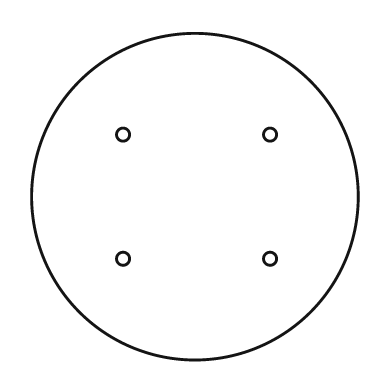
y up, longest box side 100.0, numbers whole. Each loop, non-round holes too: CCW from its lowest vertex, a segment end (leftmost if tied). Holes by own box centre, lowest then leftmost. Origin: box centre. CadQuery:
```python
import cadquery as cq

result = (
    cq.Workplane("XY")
    .moveTo(0.0, 0.0)
    .circle(50.0)
    .moveTo(-22.0, -19.0)
    .circle(2.0)
    .moveTo(23.0, -19.0)
    .circle(2.0)
    .moveTo(-22.0, 19.0)
    .circle(2.0)
    .moveTo(23.0, 19.0)
    .circle(2.0)
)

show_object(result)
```